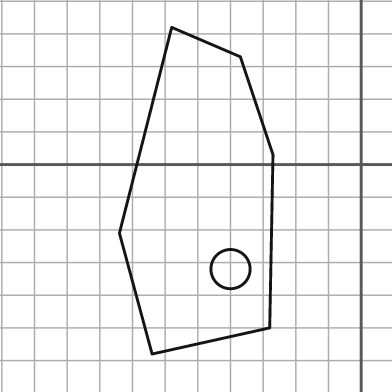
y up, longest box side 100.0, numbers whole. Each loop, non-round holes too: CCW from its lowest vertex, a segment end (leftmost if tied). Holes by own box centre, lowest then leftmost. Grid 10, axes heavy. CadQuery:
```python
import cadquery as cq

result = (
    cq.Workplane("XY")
    .moveTo(-64.0, -58.0)
    .lineTo(-28.0, -50.0)
    .lineTo(-27.0, 3.0)
    .lineTo(-37.0, 33.0)
    .lineTo(-58.0, 42.0)
    .lineTo(-74.0, -21.0)
    .close()
    .moveTo(-40.0, -32.0)
    .circle(6.0)
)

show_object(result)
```